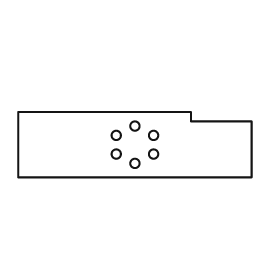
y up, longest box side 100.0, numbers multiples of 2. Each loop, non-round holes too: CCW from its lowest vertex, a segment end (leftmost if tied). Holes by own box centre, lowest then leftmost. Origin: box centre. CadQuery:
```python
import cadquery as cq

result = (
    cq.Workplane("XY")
    .moveTo(-50.0, -14.0)
    .lineTo(50.0, -14.0)
    .lineTo(50.0, 10.0)
    .lineTo(24.0, 10.0)
    .lineTo(24.0, 14.0)
    .lineTo(-50.0, 14.0)
    .close()
    .moveTo(0.0, -8.0)
    .circle(2.0)
    .moveTo(-8.0, -4.0)
    .circle(2.0)
    .moveTo(8.0, -4.0)
    .circle(2.0)
    .moveTo(-8.0, 4.0)
    .circle(2.0)
    .moveTo(8.0, 4.0)
    .circle(2.0)
    .moveTo(0.0, 8.0)
    .circle(2.0)
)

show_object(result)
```